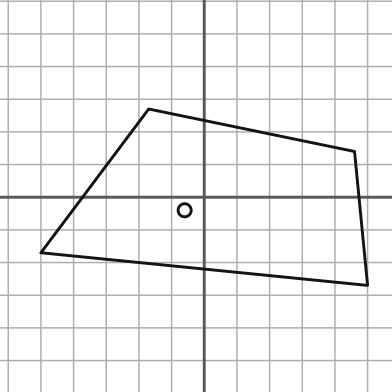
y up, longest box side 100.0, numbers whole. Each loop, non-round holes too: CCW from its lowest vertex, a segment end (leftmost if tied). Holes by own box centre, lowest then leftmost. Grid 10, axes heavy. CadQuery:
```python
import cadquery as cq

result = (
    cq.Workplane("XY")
    .moveTo(50.0, -27.0)
    .lineTo(46.0, 14.0)
    .lineTo(-17.0, 27.0)
    .lineTo(-50.0, -17.0)
    .close()
    .moveTo(-6.0, -4.0)
    .circle(2.0)
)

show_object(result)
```